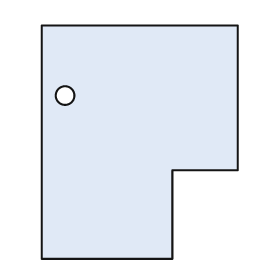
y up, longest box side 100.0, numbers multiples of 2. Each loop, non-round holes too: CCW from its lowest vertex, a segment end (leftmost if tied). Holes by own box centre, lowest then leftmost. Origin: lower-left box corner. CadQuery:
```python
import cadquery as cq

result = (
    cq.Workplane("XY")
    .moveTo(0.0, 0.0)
    .lineTo(56.0, 0.0)
    .lineTo(56.0, 38.0)
    .lineTo(84.0, 38.0)
    .lineTo(84.0, 100.0)
    .lineTo(0.0, 100.0)
    .close()
    .moveTo(10.0, 70.0)
    .circle(4.0)
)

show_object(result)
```